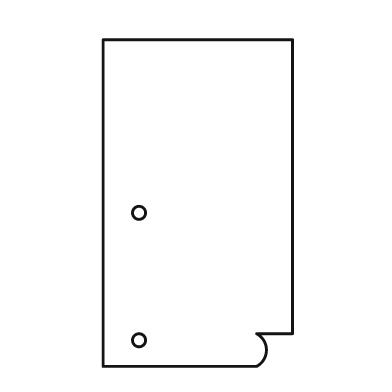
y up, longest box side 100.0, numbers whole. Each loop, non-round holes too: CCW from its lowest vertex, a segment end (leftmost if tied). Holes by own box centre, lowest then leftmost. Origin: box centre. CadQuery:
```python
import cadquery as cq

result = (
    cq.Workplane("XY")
    .moveTo(-29.0, -50.0)
    .lineTo(18.0, -50.0)
    .threePointArc((21.0, -45.0), (18.0, -40.0))
    .lineTo(29.0, -40.0)
    .lineTo(29.0, 50.0)
    .lineTo(-29.0, 50.0)
    .close()
    .moveTo(-18.0, -42.0)
    .circle(2.0)
    .moveTo(-18.0, -3.0)
    .circle(2.0)
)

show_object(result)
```